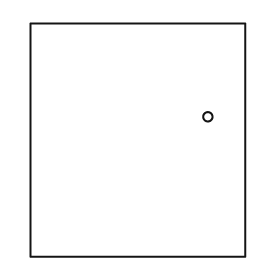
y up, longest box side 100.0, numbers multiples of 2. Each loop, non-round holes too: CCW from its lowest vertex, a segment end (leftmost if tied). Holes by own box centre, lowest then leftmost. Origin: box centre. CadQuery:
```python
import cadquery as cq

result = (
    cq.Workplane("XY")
    .moveTo(-46.0, -50.0)
    .lineTo(46.0, -50.0)
    .lineTo(46.0, 50.0)
    .lineTo(-46.0, 50.0)
    .close()
    .moveTo(30.0, 10.0)
    .circle(2.0)
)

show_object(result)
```